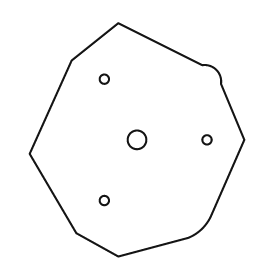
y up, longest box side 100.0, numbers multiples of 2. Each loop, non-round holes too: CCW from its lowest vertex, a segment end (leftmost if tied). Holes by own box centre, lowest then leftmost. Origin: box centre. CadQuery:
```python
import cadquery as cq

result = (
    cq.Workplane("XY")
    .moveTo(-8.0, -50.0)
    .lineTo(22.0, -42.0)
    .threePointArc((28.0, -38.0), (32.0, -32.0))
    .lineTo(46.0, 0.0)
    .lineTo(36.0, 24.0)
    .threePointArc((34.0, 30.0), (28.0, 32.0))
    .lineTo(-8.0, 50.0)
    .lineTo(-28.0, 34.0)
    .lineTo(-46.0, -6.0)
    .lineTo(-26.0, -40.0)
    .close()
    .moveTo(-14.0, -26.0)
    .circle(2.0)
    .moveTo(0.0, 0.0)
    .circle(4.0)
    .moveTo(30.0, 0.0)
    .circle(2.0)
    .moveTo(-14.0, 26.0)
    .circle(2.0)
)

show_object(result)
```